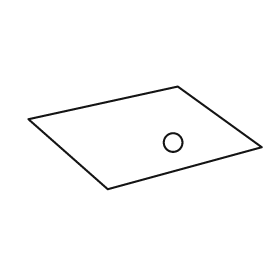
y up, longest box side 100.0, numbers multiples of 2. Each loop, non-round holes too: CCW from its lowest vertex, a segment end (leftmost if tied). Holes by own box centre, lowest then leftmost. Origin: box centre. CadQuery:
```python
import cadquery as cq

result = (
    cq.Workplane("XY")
    .moveTo(-16.0, -22.0)
    .lineTo(50.0, -4.0)
    .lineTo(14.0, 22.0)
    .lineTo(-50.0, 8.0)
    .close()
    .moveTo(12.0, -2.0)
    .circle(4.0)
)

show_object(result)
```